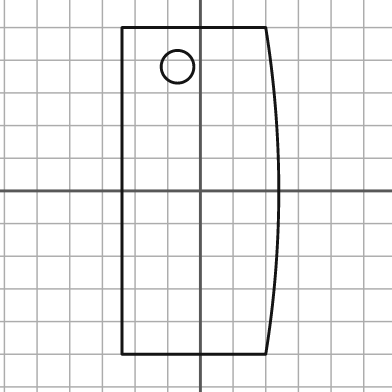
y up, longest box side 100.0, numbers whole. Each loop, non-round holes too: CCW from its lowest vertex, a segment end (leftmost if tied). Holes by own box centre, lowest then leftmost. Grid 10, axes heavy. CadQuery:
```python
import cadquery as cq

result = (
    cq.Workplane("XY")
    .moveTo(-24.0, -50.0)
    .lineTo(20.0, -50.0)
    .threePointArc((24.0, 0.0), (20.0, 50.0))
    .lineTo(-24.0, 50.0)
    .close()
    .moveTo(-7.0, 38.0)
    .circle(5.0)
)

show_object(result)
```